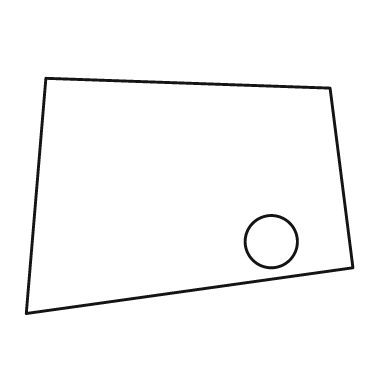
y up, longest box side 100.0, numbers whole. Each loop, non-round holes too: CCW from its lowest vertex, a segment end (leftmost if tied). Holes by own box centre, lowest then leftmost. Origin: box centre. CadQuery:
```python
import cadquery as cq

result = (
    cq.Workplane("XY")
    .moveTo(-50.0, -36.0)
    .lineTo(50.0, -22.0)
    .lineTo(43.0, 33.0)
    .lineTo(-44.0, 36.0)
    .close()
    .moveTo(25.0, -14.0)
    .circle(8.0)
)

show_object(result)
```